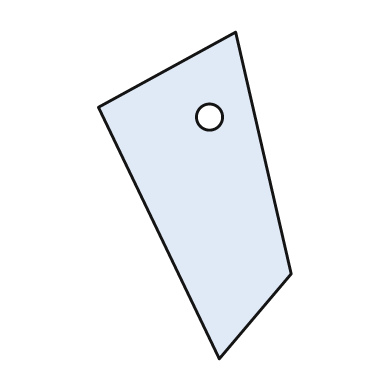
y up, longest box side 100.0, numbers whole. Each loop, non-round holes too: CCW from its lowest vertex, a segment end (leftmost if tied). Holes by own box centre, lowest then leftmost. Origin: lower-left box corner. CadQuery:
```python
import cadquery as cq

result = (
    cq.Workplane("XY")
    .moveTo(37.0, 0.0)
    .lineTo(59.0, 26.0)
    .lineTo(42.0, 100.0)
    .lineTo(0.0, 77.0)
    .close()
    .moveTo(34.0, 74.0)
    .circle(4.0)
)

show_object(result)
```